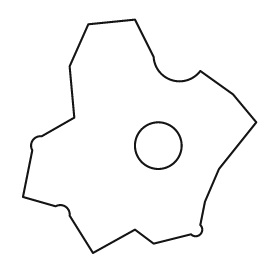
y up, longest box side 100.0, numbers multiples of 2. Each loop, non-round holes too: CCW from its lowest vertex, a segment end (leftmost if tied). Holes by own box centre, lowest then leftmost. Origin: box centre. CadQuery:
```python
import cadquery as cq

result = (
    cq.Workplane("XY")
    .moveTo(-20.0, -50.0)
    .lineTo(-2.0, -40.0)
    .lineTo(6.0, -46.0)
    .lineTo(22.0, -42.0)
    .threePointArc((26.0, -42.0), (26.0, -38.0))
    .lineTo(28.0, -28.0)
    .lineTo(34.0, -14.0)
    .lineTo(50.0, 6.0)
    .lineTo(40.0, 18.0)
    .lineTo(26.0, 28.0)
    .threePointArc((14.0, 24.0), (6.0, 34.0))
    .lineTo(-2.0, 50.0)
    .lineTo(-22.0, 48.0)
    .lineTo(-30.0, 30.0)
    .lineTo(-28.0, 8.0)
    .lineTo(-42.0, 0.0)
    .threePointArc((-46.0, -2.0), (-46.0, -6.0))
    .lineTo(-50.0, -26.0)
    .lineTo(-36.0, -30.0)
    .threePointArc((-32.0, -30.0), (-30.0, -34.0))
    .close()
    .moveTo(8.0, -4.0)
    .circle(10.0)
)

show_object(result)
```